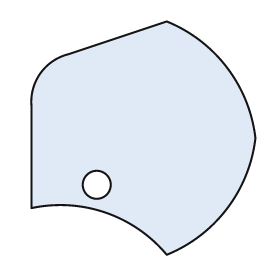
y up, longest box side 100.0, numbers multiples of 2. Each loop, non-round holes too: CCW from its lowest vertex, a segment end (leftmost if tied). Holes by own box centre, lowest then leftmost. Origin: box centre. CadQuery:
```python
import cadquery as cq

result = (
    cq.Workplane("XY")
    .moveTo(10.0, -50.0)
    .threePointArc((36.0, -30.0), (48.0, 0.0))
    .threePointArc((36.0, 30.0), (10.0, 50.0))
    .lineTo(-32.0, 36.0)
    .threePointArc((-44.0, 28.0), (-48.0, 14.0))
    .lineTo(-48.0, -30.0)
    .threePointArc((-16.0, -32.0), (10.0, -50.0))
    .close()
    .moveTo(-20.0, -20.0)
    .circle(6.0)
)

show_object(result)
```